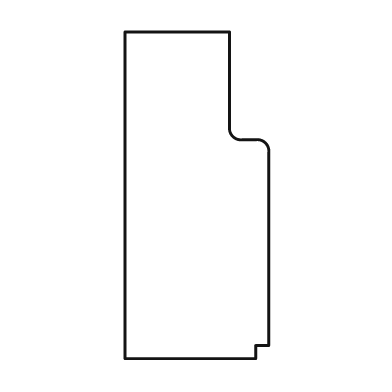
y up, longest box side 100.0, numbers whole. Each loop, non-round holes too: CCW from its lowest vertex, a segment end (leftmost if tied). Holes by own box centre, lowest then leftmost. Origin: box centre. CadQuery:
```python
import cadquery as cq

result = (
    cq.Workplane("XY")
    .moveTo(-22.0, -50.0)
    .lineTo(18.0, -50.0)
    .lineTo(18.0, -46.0)
    .lineTo(22.0, -46.0)
    .lineTo(22.0, 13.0)
    .threePointArc((21.0, 16.0), (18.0, 17.0))
    .lineTo(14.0, 17.0)
    .threePointArc((11.0, 18.0), (10.0, 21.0))
    .lineTo(10.0, 50.0)
    .lineTo(-22.0, 50.0)
    .close()
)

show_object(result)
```